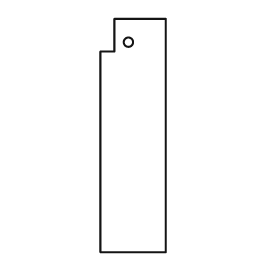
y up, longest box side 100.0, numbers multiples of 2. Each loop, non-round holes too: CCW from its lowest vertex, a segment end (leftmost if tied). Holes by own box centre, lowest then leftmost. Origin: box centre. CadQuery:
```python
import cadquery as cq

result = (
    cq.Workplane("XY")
    .moveTo(-14.0, -50.0)
    .lineTo(14.0, -50.0)
    .lineTo(14.0, 50.0)
    .lineTo(-8.0, 50.0)
    .lineTo(-8.0, 36.0)
    .lineTo(-14.0, 36.0)
    .close()
    .moveTo(-2.0, 40.0)
    .circle(2.0)
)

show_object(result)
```